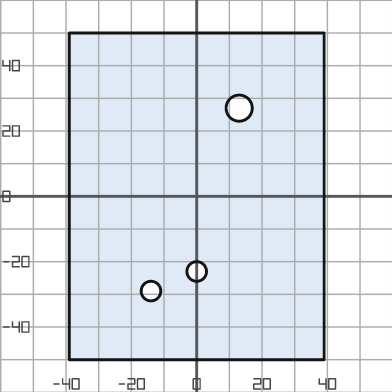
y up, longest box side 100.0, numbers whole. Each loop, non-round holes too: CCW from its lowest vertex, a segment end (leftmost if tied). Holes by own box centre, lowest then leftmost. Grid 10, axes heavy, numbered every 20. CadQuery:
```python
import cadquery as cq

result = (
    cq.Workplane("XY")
    .moveTo(-39.0, -50.0)
    .lineTo(39.0, -50.0)
    .lineTo(39.0, 50.0)
    .lineTo(-39.0, 50.0)
    .close()
    .moveTo(-14.0, -29.0)
    .circle(3.0)
    .moveTo(0.0, -23.0)
    .circle(3.0)
    .moveTo(13.0, 27.0)
    .circle(4.0)
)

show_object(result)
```